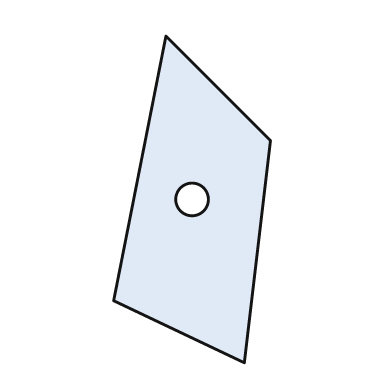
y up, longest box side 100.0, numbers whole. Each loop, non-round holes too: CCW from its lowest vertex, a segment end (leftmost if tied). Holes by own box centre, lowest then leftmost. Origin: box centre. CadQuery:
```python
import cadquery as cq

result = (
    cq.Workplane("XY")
    .moveTo(16.0, -50.0)
    .lineTo(24.0, 18.0)
    .lineTo(-8.0, 50.0)
    .lineTo(-24.0, -31.0)
    .close()
    .moveTo(0.0, 0.0)
    .circle(5.0)
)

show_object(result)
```